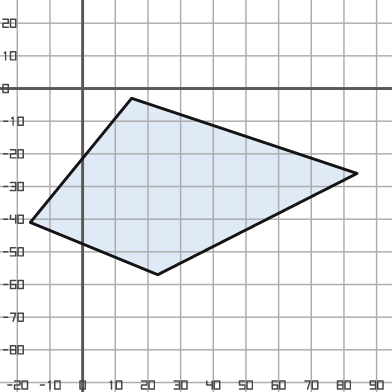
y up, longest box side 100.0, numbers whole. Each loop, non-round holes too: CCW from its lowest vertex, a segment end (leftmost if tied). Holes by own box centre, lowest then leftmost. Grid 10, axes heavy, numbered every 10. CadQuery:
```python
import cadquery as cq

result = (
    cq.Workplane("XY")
    .moveTo(23.0, -57.0)
    .lineTo(84.0, -26.0)
    .lineTo(15.0, -3.0)
    .lineTo(-16.0, -41.0)
    .close()
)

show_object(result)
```